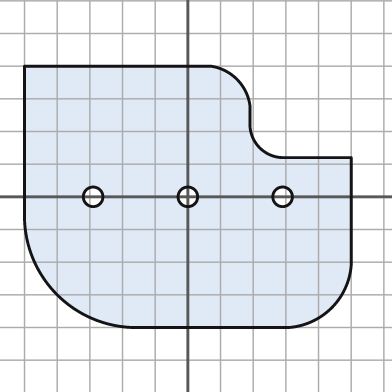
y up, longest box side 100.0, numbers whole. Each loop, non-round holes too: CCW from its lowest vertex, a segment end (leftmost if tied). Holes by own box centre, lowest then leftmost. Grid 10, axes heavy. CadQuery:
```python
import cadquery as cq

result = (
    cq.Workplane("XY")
    .moveTo(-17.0, -40.0)
    .lineTo(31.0, -40.0)
    .threePointArc((44.0, -34.0), (50.0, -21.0))
    .lineTo(50.0, 12.0)
    .lineTo(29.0, 12.0)
    .threePointArc((22.0, 15.0), (19.0, 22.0))
    .lineTo(19.0, 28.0)
    .threePointArc((15.0, 36.0), (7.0, 40.0))
    .lineTo(-50.0, 40.0)
    .lineTo(-50.0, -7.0)
    .threePointArc((-40.0, -30.0), (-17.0, -40.0))
    .close()
    .moveTo(-29.0, 0.0)
    .circle(3.0)
    .moveTo(0.0, 0.0)
    .circle(3.0)
    .moveTo(29.0, 0.0)
    .circle(3.0)
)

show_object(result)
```